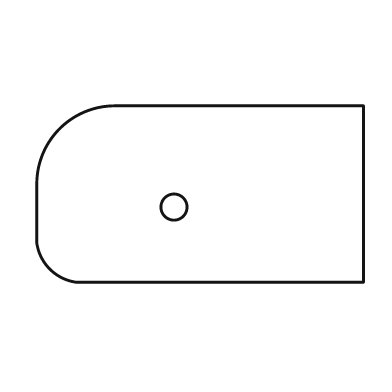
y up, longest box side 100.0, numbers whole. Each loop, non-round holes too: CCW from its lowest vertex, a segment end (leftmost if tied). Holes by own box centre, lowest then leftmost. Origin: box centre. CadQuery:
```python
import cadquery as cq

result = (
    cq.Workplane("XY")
    .moveTo(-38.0, -27.0)
    .lineTo(50.0, -27.0)
    .lineTo(50.0, 27.0)
    .lineTo(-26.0, 27.0)
    .threePointArc((-43.0, 20.0), (-50.0, 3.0))
    .lineTo(-50.0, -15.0)
    .threePointArc((-46.0, -23.0), (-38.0, -27.0))
    .close()
    .moveTo(-8.0, -4.0)
    .circle(4.0)
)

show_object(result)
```